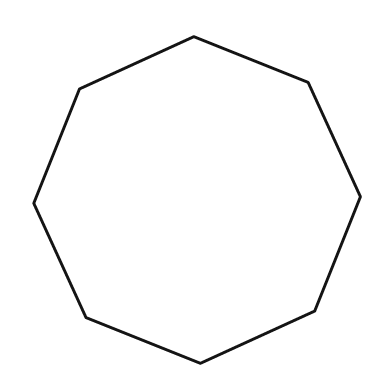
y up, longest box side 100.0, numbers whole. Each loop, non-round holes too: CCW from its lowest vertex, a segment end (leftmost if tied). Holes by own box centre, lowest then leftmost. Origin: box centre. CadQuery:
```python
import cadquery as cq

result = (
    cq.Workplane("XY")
    .moveTo(1.0, -50.0)
    .lineTo(36.0, -34.0)
    .lineTo(50.0, 1.0)
    .lineTo(34.0, 36.0)
    .lineTo(-1.0, 50.0)
    .lineTo(-36.0, 34.0)
    .lineTo(-50.0, -1.0)
    .lineTo(-34.0, -36.0)
    .close()
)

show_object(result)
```